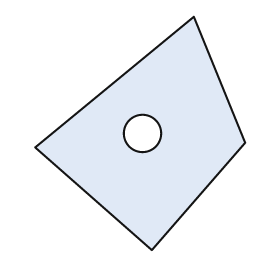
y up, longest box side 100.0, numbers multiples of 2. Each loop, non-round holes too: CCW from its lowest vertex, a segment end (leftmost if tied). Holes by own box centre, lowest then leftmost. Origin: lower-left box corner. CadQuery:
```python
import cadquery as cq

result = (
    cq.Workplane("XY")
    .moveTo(50.0, 0.0)
    .lineTo(90.0, 46.0)
    .lineTo(68.0, 100.0)
    .lineTo(0.0, 44.0)
    .close()
    .moveTo(46.0, 50.0)
    .circle(8.0)
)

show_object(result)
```